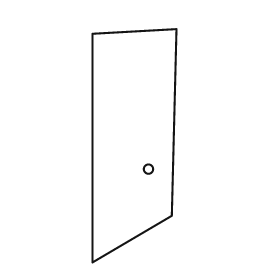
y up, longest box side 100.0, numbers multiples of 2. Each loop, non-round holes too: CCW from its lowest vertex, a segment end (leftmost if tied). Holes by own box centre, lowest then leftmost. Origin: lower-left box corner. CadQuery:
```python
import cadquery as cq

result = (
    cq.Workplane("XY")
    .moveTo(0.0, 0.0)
    .lineTo(34.0, 20.0)
    .lineTo(36.0, 100.0)
    .lineTo(0.0, 98.0)
    .close()
    .moveTo(24.0, 40.0)
    .circle(2.0)
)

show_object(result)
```